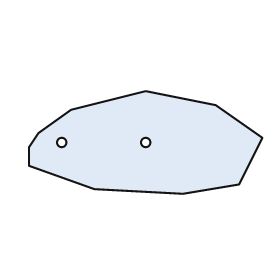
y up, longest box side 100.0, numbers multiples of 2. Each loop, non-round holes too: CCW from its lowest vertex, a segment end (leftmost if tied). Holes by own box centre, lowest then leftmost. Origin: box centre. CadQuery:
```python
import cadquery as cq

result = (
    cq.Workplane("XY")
    .moveTo(16.0, -22.0)
    .lineTo(40.0, -18.0)
    .lineTo(50.0, 2.0)
    .lineTo(30.0, 16.0)
    .lineTo(0.0, 22.0)
    .lineTo(-32.0, 14.0)
    .lineTo(-46.0, 4.0)
    .lineTo(-50.0, -2.0)
    .lineTo(-50.0, -10.0)
    .lineTo(-22.0, -20.0)
    .close()
    .moveTo(-36.0, 0.0)
    .circle(2.0)
    .moveTo(0.0, 0.0)
    .circle(2.0)
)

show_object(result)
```